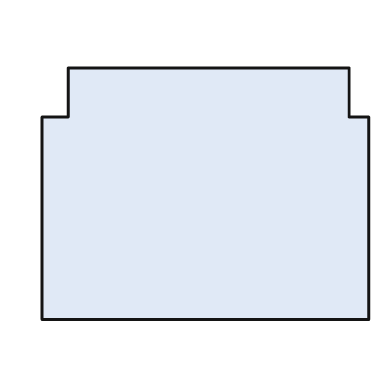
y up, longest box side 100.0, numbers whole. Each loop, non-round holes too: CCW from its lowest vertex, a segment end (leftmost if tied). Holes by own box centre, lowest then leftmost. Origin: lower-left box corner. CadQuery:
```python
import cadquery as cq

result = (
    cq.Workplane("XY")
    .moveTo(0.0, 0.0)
    .lineTo(100.0, 0.0)
    .lineTo(100.0, 62.0)
    .lineTo(94.0, 62.0)
    .lineTo(94.0, 77.0)
    .lineTo(8.0, 77.0)
    .lineTo(8.0, 62.0)
    .lineTo(0.0, 62.0)
    .close()
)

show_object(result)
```